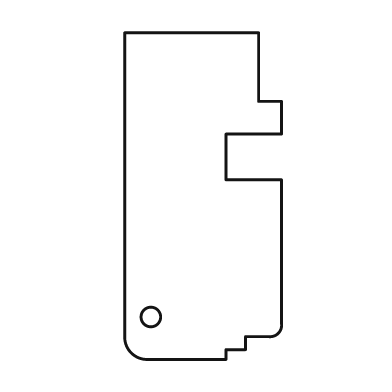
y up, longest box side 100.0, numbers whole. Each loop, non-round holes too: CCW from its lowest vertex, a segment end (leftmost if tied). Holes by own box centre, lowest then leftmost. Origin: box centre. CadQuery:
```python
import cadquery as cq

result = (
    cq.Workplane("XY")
    .moveTo(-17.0, -50.0)
    .lineTo(7.0, -50.0)
    .lineTo(7.0, -47.0)
    .lineTo(13.0, -47.0)
    .lineTo(13.0, -43.0)
    .lineTo(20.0, -43.0)
    .threePointArc((23.0, -42.0), (24.0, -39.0))
    .lineTo(24.0, 5.0)
    .lineTo(7.0, 5.0)
    .lineTo(7.0, 19.0)
    .lineTo(24.0, 19.0)
    .lineTo(24.0, 29.0)
    .lineTo(17.0, 29.0)
    .lineTo(17.0, 50.0)
    .lineTo(-24.0, 50.0)
    .lineTo(-24.0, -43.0)
    .threePointArc((-22.0, -48.0), (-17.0, -50.0))
    .close()
    .moveTo(-16.0, -37.0)
    .circle(3.0)
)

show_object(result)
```